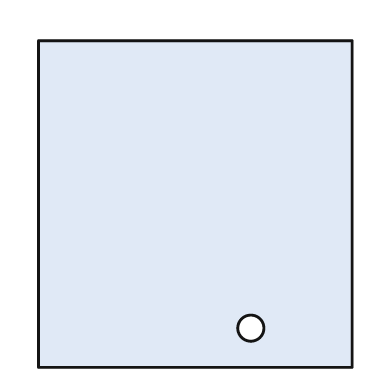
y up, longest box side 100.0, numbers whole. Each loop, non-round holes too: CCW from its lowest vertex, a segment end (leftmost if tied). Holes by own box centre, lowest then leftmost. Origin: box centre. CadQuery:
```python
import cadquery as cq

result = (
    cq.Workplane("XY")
    .moveTo(-48.0, -50.0)
    .lineTo(48.0, -50.0)
    .lineTo(48.0, 50.0)
    .lineTo(-48.0, 50.0)
    .close()
    .moveTo(17.0, -38.0)
    .circle(4.0)
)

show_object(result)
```